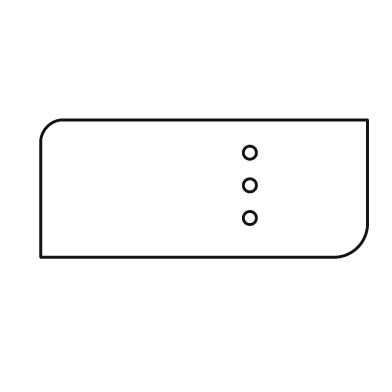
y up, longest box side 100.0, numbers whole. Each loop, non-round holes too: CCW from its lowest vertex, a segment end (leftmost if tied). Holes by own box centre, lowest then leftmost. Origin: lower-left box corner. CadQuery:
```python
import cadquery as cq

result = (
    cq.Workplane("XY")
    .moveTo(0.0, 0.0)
    .lineTo(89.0, 0.0)
    .threePointArc((97.0, 3.0), (100.0, 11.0))
    .lineTo(100.0, 42.0)
    .lineTo(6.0, 42.0)
    .threePointArc((2.0, 40.0), (0.0, 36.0))
    .close()
    .moveTo(64.0, 12.0)
    .circle(2.0)
    .moveTo(64.0, 22.0)
    .circle(2.0)
    .moveTo(64.0, 32.0)
    .circle(2.0)
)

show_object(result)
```